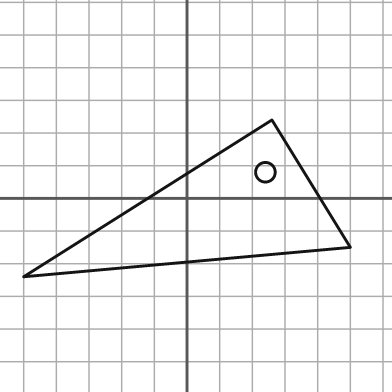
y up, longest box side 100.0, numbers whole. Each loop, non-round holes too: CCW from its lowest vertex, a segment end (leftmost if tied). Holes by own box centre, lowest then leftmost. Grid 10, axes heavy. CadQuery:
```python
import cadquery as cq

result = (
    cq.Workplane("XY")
    .moveTo(-50.0, -24.0)
    .lineTo(50.0, -15.0)
    .lineTo(26.0, 24.0)
    .close()
    .moveTo(24.0, 8.0)
    .circle(3.0)
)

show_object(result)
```